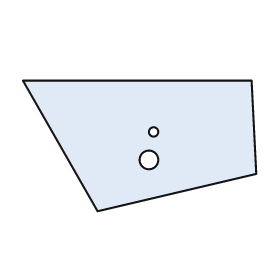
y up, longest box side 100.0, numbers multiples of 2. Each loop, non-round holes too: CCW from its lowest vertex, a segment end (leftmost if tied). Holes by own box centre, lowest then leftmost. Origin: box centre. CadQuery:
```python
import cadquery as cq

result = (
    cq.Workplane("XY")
    .moveTo(-18.0, -28.0)
    .lineTo(50.0, -12.0)
    .lineTo(48.0, 28.0)
    .lineTo(-50.0, 28.0)
    .close()
    .moveTo(4.0, -6.0)
    .circle(4.0)
    .moveTo(6.0, 6.0)
    .circle(2.0)
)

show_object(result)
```